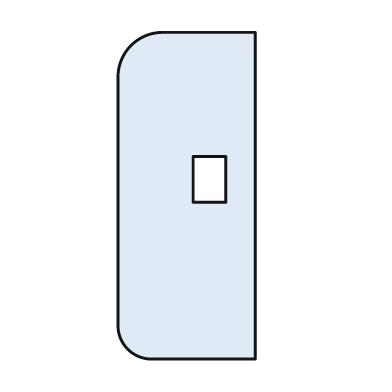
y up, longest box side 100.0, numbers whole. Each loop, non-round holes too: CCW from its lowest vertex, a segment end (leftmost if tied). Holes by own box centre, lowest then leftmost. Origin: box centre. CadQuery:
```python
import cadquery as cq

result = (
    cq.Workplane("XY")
    .moveTo(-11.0, -50.0)
    .lineTo(21.0, -50.0)
    .lineTo(21.0, 50.0)
    .lineTo(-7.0, 50.0)
    .threePointArc((-17.0, 46.0), (-21.0, 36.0))
    .lineTo(-21.0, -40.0)
    .threePointArc((-18.0, -47.0), (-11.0, -50.0))
    .close()
    .moveTo(2.0, -2.0)
    .lineTo(12.0, -2.0)
    .lineTo(12.0, 12.0)
    .lineTo(2.0, 12.0)
    .close()
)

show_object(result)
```